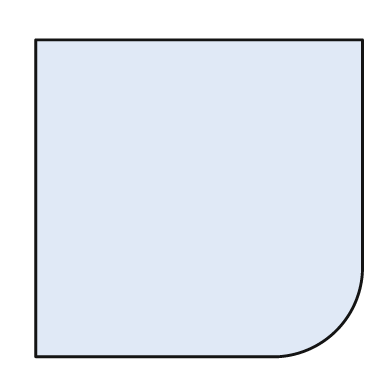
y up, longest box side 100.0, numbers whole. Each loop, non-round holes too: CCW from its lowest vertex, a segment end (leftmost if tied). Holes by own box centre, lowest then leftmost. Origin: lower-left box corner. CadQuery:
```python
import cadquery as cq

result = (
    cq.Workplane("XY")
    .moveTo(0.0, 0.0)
    .lineTo(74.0, 0.0)
    .threePointArc((92.0, 8.0), (100.0, 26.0))
    .lineTo(100.0, 97.0)
    .lineTo(0.0, 97.0)
    .close()
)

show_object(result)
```